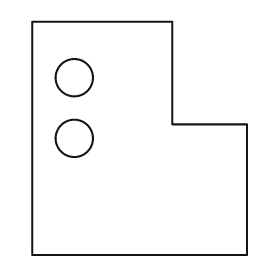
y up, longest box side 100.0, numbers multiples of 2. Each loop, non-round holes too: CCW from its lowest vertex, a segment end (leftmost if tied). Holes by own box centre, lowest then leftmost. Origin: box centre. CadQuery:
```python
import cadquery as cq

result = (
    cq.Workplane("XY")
    .moveTo(-46.0, -50.0)
    .lineTo(46.0, -50.0)
    .lineTo(46.0, 6.0)
    .lineTo(14.0, 6.0)
    .lineTo(14.0, 50.0)
    .lineTo(-46.0, 50.0)
    .close()
    .moveTo(-28.0, 0.0)
    .circle(8.0)
    .moveTo(-28.0, 26.0)
    .circle(8.0)
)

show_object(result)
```